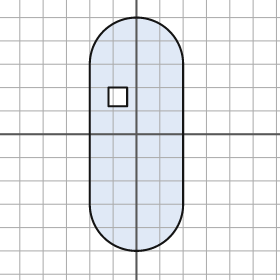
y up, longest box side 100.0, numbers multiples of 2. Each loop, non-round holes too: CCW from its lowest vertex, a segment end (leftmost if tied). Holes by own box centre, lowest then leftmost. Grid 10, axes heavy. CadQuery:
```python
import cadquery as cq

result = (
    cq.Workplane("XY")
    .moveTo(-20.0, -30.0)
    .threePointArc((0.0, -50.0), (20.0, -30.0))
    .lineTo(20.0, 30.0)
    .threePointArc((0.0, 50.0), (-20.0, 30.0))
    .close()
    .moveTo(-12.0, 12.0)
    .lineTo(-4.0, 12.0)
    .lineTo(-4.0, 20.0)
    .lineTo(-12.0, 20.0)
    .close()
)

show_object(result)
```